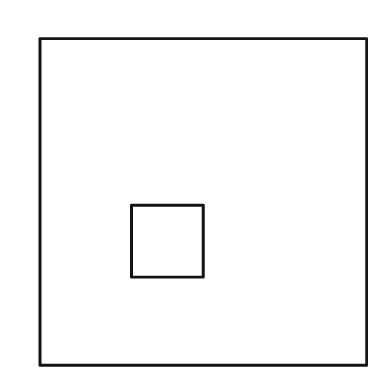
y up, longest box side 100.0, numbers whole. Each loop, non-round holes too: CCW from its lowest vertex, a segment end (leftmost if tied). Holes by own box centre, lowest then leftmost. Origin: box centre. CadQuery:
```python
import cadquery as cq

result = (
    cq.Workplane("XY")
    .moveTo(-50.0, -50.0)
    .lineTo(50.0, -50.0)
    .lineTo(50.0, 50.0)
    .lineTo(-50.0, 50.0)
    .close()
    .moveTo(-22.0, -23.0)
    .lineTo(0.0, -23.0)
    .lineTo(0.0, -1.0)
    .lineTo(-22.0, -1.0)
    .close()
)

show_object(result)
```